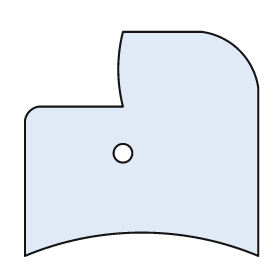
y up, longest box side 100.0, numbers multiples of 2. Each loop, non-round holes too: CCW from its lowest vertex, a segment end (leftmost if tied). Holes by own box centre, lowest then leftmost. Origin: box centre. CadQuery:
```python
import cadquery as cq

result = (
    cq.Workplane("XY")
    .moveTo(-50.0, -48.0)
    .threePointArc((0.0, -38.0), (50.0, -48.0))
    .lineTo(50.0, 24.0)
    .threePointArc((42.0, 40.0), (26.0, 48.0))
    .lineTo(-8.0, 48.0)
    .threePointArc((-10.0, 32.0), (-8.0, 16.0))
    .lineTo(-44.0, 16.0)
    .threePointArc((-48.0, 14.0), (-50.0, 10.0))
    .close()
    .moveTo(-8.0, -4.0)
    .circle(4.0)
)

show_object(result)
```